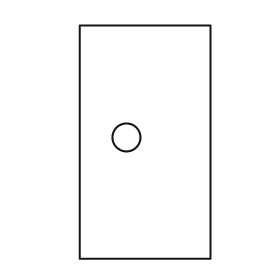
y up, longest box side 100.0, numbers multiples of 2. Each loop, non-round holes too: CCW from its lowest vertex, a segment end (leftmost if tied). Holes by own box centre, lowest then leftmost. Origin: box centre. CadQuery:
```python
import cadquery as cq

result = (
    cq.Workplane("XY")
    .moveTo(-28.0, -50.0)
    .lineTo(28.0, -50.0)
    .lineTo(28.0, 50.0)
    .lineTo(-28.0, 50.0)
    .close()
    .moveTo(-8.0, 2.0)
    .circle(6.0)
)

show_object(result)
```